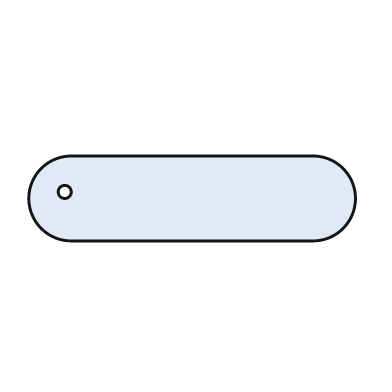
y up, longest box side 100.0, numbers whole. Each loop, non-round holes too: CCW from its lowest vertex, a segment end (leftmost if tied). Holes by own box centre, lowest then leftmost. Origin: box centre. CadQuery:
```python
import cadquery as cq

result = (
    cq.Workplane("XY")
    .moveTo(-37.0, -13.0)
    .lineTo(37.0, -13.0)
    .threePointArc((50.0, 0.0), (37.0, 13.0))
    .lineTo(-37.0, 13.0)
    .threePointArc((-50.0, 0.0), (-37.0, -13.0))
    .close()
    .moveTo(-39.0, 2.0)
    .circle(2.0)
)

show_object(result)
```